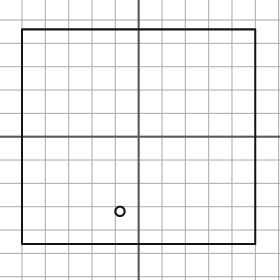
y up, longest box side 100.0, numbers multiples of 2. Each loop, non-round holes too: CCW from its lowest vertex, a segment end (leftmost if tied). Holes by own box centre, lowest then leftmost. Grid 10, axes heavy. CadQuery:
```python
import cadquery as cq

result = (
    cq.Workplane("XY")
    .moveTo(-50.0, -46.0)
    .lineTo(50.0, -46.0)
    .lineTo(50.0, 46.0)
    .lineTo(-50.0, 46.0)
    .close()
    .moveTo(-8.0, -32.0)
    .circle(2.0)
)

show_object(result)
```